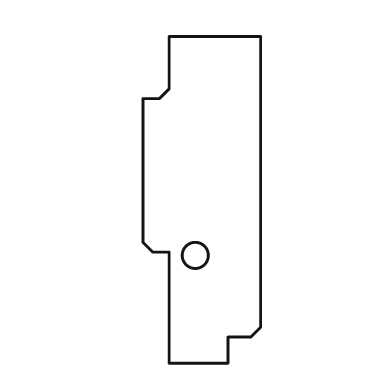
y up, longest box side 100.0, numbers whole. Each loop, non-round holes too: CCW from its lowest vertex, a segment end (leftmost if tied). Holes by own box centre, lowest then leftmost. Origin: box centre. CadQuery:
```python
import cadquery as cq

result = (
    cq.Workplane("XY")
    .moveTo(-10.0, -50.0)
    .lineTo(8.0, -50.0)
    .lineTo(8.0, -42.0)
    .lineTo(15.0, -42.0)
    .lineTo(18.0, -39.0)
    .lineTo(18.0, 50.0)
    .lineTo(-10.0, 50.0)
    .lineTo(-10.0, 34.0)
    .lineTo(-13.0, 31.0)
    .lineTo(-18.0, 31.0)
    .lineTo(-18.0, -13.0)
    .lineTo(-15.0, -16.0)
    .lineTo(-10.0, -16.0)
    .close()
    .moveTo(-2.0, -17.0)
    .circle(4.0)
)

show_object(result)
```